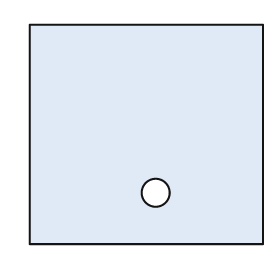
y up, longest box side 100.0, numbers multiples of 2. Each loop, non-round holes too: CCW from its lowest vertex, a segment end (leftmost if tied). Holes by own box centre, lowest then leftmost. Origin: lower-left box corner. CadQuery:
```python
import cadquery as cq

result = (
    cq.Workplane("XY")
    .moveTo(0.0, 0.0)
    .lineTo(100.0, 0.0)
    .lineTo(100.0, 94.0)
    .lineTo(0.0, 94.0)
    .close()
    .moveTo(54.0, 22.0)
    .circle(6.0)
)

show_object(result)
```